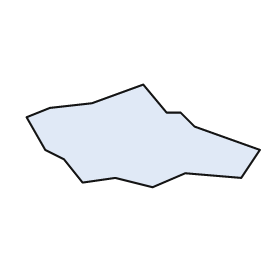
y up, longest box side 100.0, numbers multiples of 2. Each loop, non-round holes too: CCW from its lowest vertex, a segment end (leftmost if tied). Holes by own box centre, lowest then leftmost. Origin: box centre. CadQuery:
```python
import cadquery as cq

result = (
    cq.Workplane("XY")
    .moveTo(4.0, -22.0)
    .lineTo(18.0, -16.0)
    .lineTo(42.0, -18.0)
    .lineTo(50.0, -6.0)
    .lineTo(22.0, 4.0)
    .lineTo(16.0, 10.0)
    .lineTo(10.0, 10.0)
    .lineTo(0.0, 22.0)
    .lineTo(-22.0, 14.0)
    .lineTo(-40.0, 12.0)
    .lineTo(-50.0, 8.0)
    .lineTo(-42.0, -6.0)
    .lineTo(-34.0, -10.0)
    .lineTo(-26.0, -20.0)
    .lineTo(-12.0, -18.0)
    .close()
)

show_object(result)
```